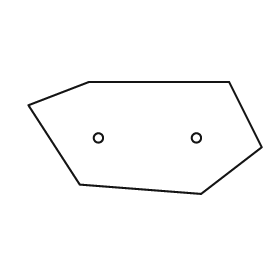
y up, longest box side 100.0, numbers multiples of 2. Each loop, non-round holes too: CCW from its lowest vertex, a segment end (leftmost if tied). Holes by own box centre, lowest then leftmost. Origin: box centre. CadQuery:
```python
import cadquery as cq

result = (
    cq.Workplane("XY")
    .moveTo(24.0, -24.0)
    .lineTo(50.0, -4.0)
    .lineTo(36.0, 24.0)
    .lineTo(-24.0, 24.0)
    .lineTo(-50.0, 14.0)
    .lineTo(-28.0, -20.0)
    .close()
    .moveTo(-20.0, 0.0)
    .circle(2.0)
    .moveTo(22.0, 0.0)
    .circle(2.0)
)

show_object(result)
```